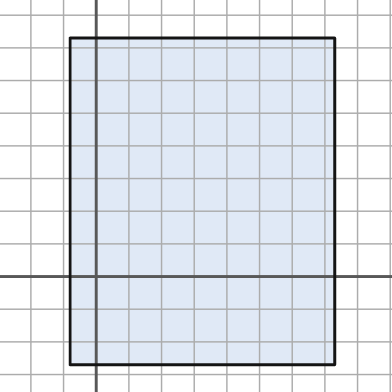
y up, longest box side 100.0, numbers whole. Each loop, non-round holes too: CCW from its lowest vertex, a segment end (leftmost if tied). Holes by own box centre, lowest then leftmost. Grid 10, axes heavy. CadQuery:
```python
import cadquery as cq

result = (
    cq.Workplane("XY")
    .moveTo(-8.0, -27.0)
    .lineTo(73.0, -27.0)
    .lineTo(73.0, 73.0)
    .lineTo(-8.0, 73.0)
    .close()
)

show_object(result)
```